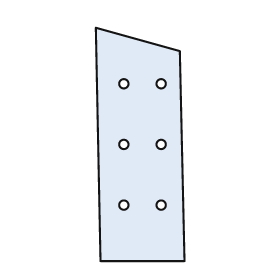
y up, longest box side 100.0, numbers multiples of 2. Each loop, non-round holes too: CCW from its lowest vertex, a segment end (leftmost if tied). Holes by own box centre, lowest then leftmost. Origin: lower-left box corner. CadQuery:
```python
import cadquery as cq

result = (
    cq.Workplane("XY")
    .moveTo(2.0, 0.0)
    .lineTo(38.0, 0.0)
    .lineTo(36.0, 90.0)
    .lineTo(0.0, 100.0)
    .close()
    .moveTo(12.0, 24.0)
    .circle(2.0)
    .moveTo(28.0, 24.0)
    .circle(2.0)
    .moveTo(12.0, 50.0)
    .circle(2.0)
    .moveTo(28.0, 50.0)
    .circle(2.0)
    .moveTo(12.0, 76.0)
    .circle(2.0)
    .moveTo(28.0, 76.0)
    .circle(2.0)
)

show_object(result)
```